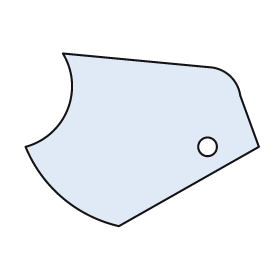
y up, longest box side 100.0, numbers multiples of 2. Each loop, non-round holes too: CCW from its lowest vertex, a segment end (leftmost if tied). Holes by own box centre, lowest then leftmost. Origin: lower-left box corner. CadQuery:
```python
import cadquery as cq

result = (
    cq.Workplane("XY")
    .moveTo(40.0, 0.0)
    .lineTo(100.0, 34.0)
    .lineTo(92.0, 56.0)
    .threePointArc((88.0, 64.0), (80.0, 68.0))
    .lineTo(16.0, 74.0)
    .threePointArc((18.0, 50.0), (0.0, 34.0))
    .threePointArc((16.0, 12.0), (40.0, 0.0))
    .close()
    .moveTo(78.0, 34.0)
    .circle(4.0)
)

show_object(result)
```